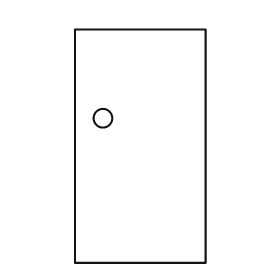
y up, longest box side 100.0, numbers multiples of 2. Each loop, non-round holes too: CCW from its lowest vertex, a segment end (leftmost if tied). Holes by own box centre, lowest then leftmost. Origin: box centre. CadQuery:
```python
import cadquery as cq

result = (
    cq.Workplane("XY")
    .moveTo(-28.0, -50.0)
    .lineTo(28.0, -50.0)
    .lineTo(28.0, 50.0)
    .lineTo(-28.0, 50.0)
    .close()
    .moveTo(-16.0, 12.0)
    .circle(4.0)
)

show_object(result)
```